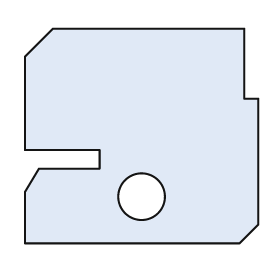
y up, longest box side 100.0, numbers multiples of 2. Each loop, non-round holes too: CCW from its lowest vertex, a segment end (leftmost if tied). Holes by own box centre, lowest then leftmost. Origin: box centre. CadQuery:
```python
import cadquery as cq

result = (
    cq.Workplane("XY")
    .moveTo(-50.0, -46.0)
    .lineTo(42.0, -46.0)
    .lineTo(50.0, -38.0)
    .lineTo(50.0, 16.0)
    .lineTo(44.0, 16.0)
    .lineTo(44.0, 46.0)
    .lineTo(-38.0, 46.0)
    .lineTo(-50.0, 34.0)
    .lineTo(-50.0, -6.0)
    .lineTo(-18.0, -6.0)
    .lineTo(-18.0, -14.0)
    .lineTo(-44.0, -14.0)
    .lineTo(-50.0, -24.0)
    .close()
    .moveTo(0.0, -26.0)
    .circle(10.0)
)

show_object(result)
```